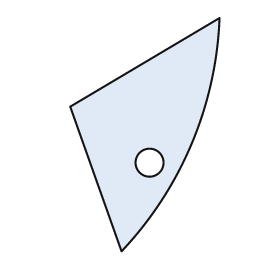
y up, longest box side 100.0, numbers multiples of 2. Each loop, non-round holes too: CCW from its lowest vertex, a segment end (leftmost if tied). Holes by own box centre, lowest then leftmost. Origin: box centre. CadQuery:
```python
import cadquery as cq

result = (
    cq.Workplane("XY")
    .moveTo(-10.0, -50.0)
    .threePointArc((20.0, -4.0), (32.0, 50.0))
    .lineTo(-32.0, 12.0)
    .close()
    .moveTo(2.0, -12.0)
    .circle(6.0)
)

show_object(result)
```